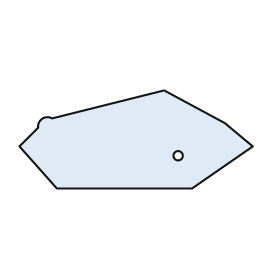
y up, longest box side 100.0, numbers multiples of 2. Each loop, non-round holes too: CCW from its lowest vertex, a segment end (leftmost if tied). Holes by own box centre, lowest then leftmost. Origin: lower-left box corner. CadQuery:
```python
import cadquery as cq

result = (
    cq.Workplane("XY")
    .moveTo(16.0, 0.0)
    .lineTo(74.0, 0.0)
    .lineTo(100.0, 18.0)
    .lineTo(88.0, 28.0)
    .lineTo(62.0, 42.0)
    .lineTo(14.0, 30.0)
    .threePointArc((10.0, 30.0), (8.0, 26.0))
    .lineTo(0.0, 18.0)
    .close()
    .moveTo(68.0, 14.0)
    .circle(2.0)
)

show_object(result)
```